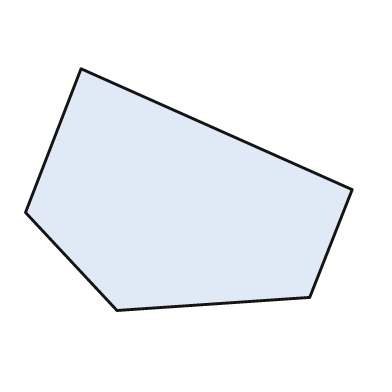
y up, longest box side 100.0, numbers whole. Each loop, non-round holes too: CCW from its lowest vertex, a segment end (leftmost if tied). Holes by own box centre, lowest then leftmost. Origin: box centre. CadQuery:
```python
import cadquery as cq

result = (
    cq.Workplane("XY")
    .moveTo(-22.0, -37.0)
    .lineTo(37.0, -33.0)
    .lineTo(50.0, 0.0)
    .lineTo(-33.0, 37.0)
    .lineTo(-50.0, -7.0)
    .close()
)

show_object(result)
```